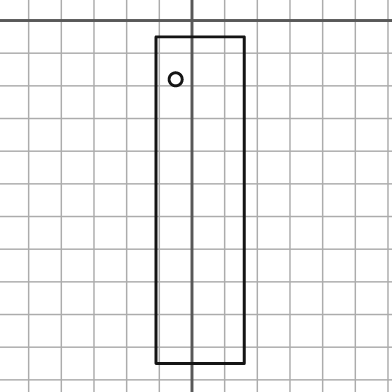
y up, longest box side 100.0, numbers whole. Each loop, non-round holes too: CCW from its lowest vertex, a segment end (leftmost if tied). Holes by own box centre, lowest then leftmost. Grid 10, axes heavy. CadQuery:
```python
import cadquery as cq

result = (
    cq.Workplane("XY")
    .moveTo(-11.0, -105.0)
    .lineTo(16.0, -105.0)
    .lineTo(16.0, -5.0)
    .lineTo(-11.0, -5.0)
    .close()
    .moveTo(-5.0, -18.0)
    .circle(2.0)
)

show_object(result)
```